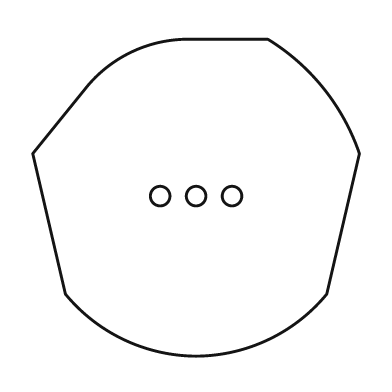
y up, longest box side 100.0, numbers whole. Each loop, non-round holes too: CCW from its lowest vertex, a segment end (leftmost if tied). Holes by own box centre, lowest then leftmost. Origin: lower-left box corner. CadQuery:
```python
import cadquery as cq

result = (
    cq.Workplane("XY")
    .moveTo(50.0, 0.0)
    .threePointArc((72.0, 5.0), (90.0, 19.0))
    .lineTo(100.0, 62.0)
    .threePointArc((89.0, 82.0), (72.0, 97.0))
    .lineTo(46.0, 97.0)
    .threePointArc((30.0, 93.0), (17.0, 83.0))
    .lineTo(0.0, 62.0)
    .lineTo(10.0, 19.0)
    .threePointArc((28.0, 5.0), (50.0, 0.0))
    .close()
    .moveTo(39.0, 49.0)
    .circle(3.0)
    .moveTo(50.0, 49.0)
    .circle(3.0)
    .moveTo(61.0, 49.0)
    .circle(3.0)
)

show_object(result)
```